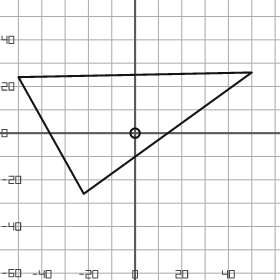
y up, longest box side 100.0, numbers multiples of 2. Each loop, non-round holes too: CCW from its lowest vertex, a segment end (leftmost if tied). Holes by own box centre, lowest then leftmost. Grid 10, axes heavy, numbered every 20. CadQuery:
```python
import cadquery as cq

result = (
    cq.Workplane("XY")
    .moveTo(-22.0, -26.0)
    .lineTo(50.0, 26.0)
    .lineTo(-50.0, 24.0)
    .close()
    .moveTo(0.0, 0.0)
    .circle(2.0)
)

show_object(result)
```